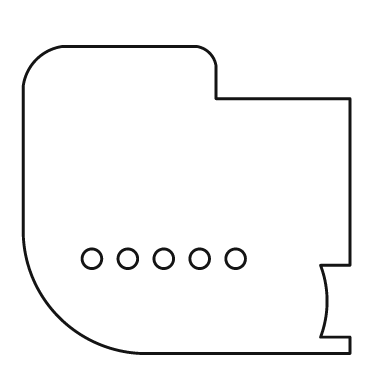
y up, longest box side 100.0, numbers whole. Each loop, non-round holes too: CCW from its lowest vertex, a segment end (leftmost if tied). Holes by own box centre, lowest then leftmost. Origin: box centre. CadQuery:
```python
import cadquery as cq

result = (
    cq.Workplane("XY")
    .moveTo(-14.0, -47.0)
    .lineTo(50.0, -47.0)
    .lineTo(50.0, -42.0)
    .lineTo(41.0, -42.0)
    .threePointArc((43.0, -31.0), (41.0, -20.0))
    .lineTo(50.0, -20.0)
    .lineTo(50.0, 31.0)
    .lineTo(9.0, 31.0)
    .lineTo(9.0, 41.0)
    .threePointArc((7.0, 45.0), (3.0, 47.0))
    .lineTo(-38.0, 47.0)
    .threePointArc((-46.0, 43.0), (-50.0, 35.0))
    .lineTo(-50.0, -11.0)
    .threePointArc((-39.0, -36.0), (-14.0, -47.0))
    .close()
    .moveTo(-29.0, -18.0)
    .circle(3.0)
    .moveTo(-18.0, -18.0)
    .circle(3.0)
    .moveTo(-7.0, -18.0)
    .circle(3.0)
    .moveTo(4.0, -18.0)
    .circle(3.0)
    .moveTo(15.0, -18.0)
    .circle(3.0)
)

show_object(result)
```